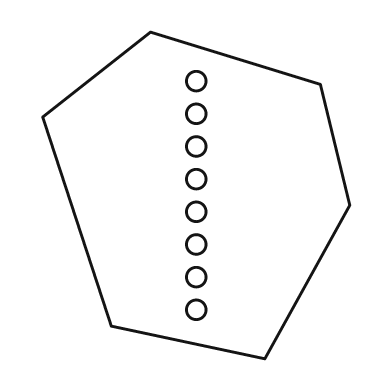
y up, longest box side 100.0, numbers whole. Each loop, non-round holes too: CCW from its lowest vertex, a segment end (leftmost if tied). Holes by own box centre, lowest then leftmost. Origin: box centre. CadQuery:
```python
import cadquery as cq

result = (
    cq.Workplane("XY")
    .moveTo(21.0, -50.0)
    .lineTo(47.0, -3.0)
    .lineTo(38.0, 34.0)
    .lineTo(-14.0, 50.0)
    .lineTo(-47.0, 24.0)
    .lineTo(-26.0, -40.0)
    .close()
    .moveTo(0.0, -35.0)
    .circle(3.0)
    .moveTo(0.0, -25.0)
    .circle(3.0)
    .moveTo(0.0, -15.0)
    .circle(3.0)
    .moveTo(0.0, -5.0)
    .circle(3.0)
    .moveTo(0.0, 5.0)
    .circle(3.0)
    .moveTo(0.0, 15.0)
    .circle(3.0)
    .moveTo(0.0, 25.0)
    .circle(3.0)
    .moveTo(0.0, 35.0)
    .circle(3.0)
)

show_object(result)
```